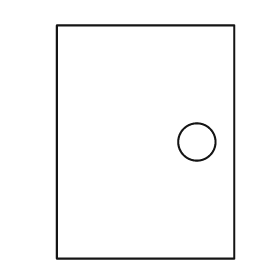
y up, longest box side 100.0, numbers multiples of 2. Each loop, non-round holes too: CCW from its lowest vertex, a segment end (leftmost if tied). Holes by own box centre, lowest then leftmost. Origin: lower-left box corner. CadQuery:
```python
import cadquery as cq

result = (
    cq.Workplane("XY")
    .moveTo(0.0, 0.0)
    .lineTo(76.0, 0.0)
    .lineTo(76.0, 100.0)
    .lineTo(0.0, 100.0)
    .close()
    .moveTo(60.0, 50.0)
    .circle(8.0)
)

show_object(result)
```